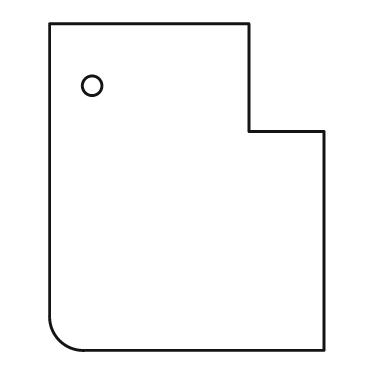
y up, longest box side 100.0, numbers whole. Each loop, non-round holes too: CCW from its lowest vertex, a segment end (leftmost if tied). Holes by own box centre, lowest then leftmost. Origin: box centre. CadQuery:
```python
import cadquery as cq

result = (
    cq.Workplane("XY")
    .moveTo(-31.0, -50.0)
    .lineTo(42.0, -50.0)
    .lineTo(42.0, 17.0)
    .lineTo(19.0, 17.0)
    .lineTo(19.0, 50.0)
    .lineTo(-42.0, 50.0)
    .lineTo(-42.0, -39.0)
    .threePointArc((-39.0, -47.0), (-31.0, -50.0))
    .close()
    .moveTo(-29.0, 31.0)
    .circle(3.0)
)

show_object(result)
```